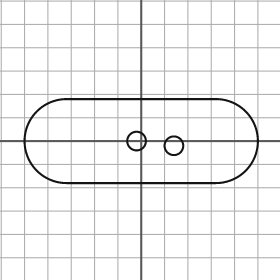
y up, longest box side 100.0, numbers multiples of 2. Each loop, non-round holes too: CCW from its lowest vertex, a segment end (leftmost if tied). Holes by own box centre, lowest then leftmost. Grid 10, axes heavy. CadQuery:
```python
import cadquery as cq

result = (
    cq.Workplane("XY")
    .moveTo(-32.0, -18.0)
    .lineTo(32.0, -18.0)
    .threePointArc((50.0, 0.0), (32.0, 18.0))
    .lineTo(-32.0, 18.0)
    .threePointArc((-50.0, 0.0), (-32.0, -18.0))
    .close()
    .moveTo(14.0, -2.0)
    .circle(4.0)
    .moveTo(-2.0, 0.0)
    .circle(4.0)
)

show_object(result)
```